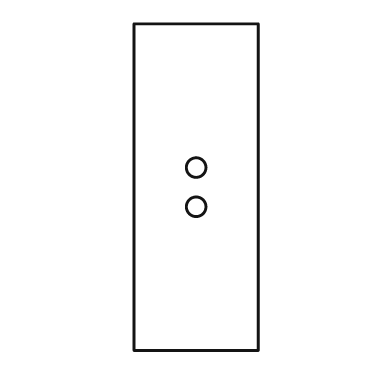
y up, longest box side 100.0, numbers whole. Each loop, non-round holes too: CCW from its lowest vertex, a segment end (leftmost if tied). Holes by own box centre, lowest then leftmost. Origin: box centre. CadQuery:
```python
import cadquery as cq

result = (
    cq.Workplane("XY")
    .moveTo(-19.0, -50.0)
    .lineTo(19.0, -50.0)
    .lineTo(19.0, 50.0)
    .lineTo(-19.0, 50.0)
    .close()
    .moveTo(0.0, -6.0)
    .circle(3.0)
    .moveTo(0.0, 6.0)
    .circle(3.0)
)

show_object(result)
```